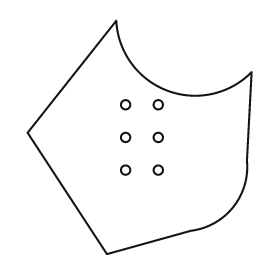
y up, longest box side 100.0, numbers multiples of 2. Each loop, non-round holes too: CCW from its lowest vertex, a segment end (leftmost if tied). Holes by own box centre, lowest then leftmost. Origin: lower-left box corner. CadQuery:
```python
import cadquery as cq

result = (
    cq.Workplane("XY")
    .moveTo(34.0, 0.0)
    .lineTo(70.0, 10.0)
    .threePointArc((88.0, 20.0), (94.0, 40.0))
    .lineTo(96.0, 78.0)
    .threePointArc((60.0, 70.0), (38.0, 100.0))
    .lineTo(0.0, 52.0)
    .close()
    .moveTo(42.0, 36.0)
    .circle(2.0)
    .moveTo(56.0, 36.0)
    .circle(2.0)
    .moveTo(42.0, 50.0)
    .circle(2.0)
    .moveTo(56.0, 50.0)
    .circle(2.0)
    .moveTo(42.0, 64.0)
    .circle(2.0)
    .moveTo(56.0, 64.0)
    .circle(2.0)
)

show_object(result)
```